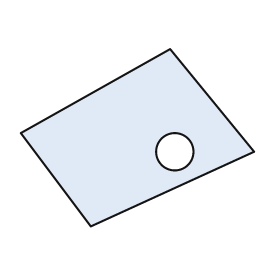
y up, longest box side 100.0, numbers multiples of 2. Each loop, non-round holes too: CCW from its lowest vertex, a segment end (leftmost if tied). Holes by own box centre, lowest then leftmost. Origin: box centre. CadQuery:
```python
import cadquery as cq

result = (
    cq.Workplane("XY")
    .moveTo(-20.0, -38.0)
    .lineTo(50.0, -6.0)
    .lineTo(14.0, 38.0)
    .lineTo(-50.0, 2.0)
    .close()
    .moveTo(16.0, -6.0)
    .circle(8.0)
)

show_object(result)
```